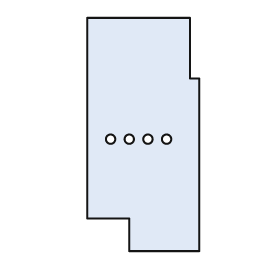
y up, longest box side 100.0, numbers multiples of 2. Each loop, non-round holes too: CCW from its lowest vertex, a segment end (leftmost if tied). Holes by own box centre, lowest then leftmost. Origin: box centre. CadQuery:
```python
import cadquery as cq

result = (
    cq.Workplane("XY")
    .moveTo(-6.0, -50.0)
    .lineTo(24.0, -50.0)
    .lineTo(24.0, 24.0)
    .lineTo(20.0, 24.0)
    .lineTo(20.0, 50.0)
    .lineTo(-24.0, 50.0)
    .lineTo(-24.0, -36.0)
    .lineTo(-6.0, -36.0)
    .close()
    .moveTo(-14.0, -2.0)
    .circle(2.0)
    .moveTo(-6.0, -2.0)
    .circle(2.0)
    .moveTo(2.0, -2.0)
    .circle(2.0)
    .moveTo(10.0, -2.0)
    .circle(2.0)
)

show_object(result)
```